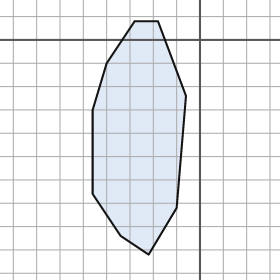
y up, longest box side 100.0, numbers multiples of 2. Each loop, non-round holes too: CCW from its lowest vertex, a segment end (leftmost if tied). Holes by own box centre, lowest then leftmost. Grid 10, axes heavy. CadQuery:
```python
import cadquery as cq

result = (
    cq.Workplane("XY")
    .moveTo(-22.0, -92.0)
    .lineTo(-10.0, -72.0)
    .lineTo(-6.0, -24.0)
    .lineTo(-18.0, 8.0)
    .lineTo(-28.0, 8.0)
    .lineTo(-40.0, -10.0)
    .lineTo(-46.0, -30.0)
    .lineTo(-46.0, -66.0)
    .lineTo(-34.0, -84.0)
    .close()
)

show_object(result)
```